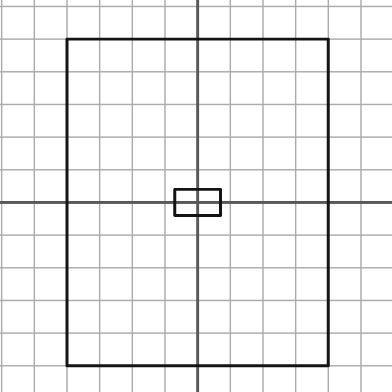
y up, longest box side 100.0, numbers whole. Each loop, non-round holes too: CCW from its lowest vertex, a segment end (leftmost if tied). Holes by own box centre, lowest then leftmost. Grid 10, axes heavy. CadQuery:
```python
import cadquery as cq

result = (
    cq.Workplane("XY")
    .moveTo(-40.0, -50.0)
    .lineTo(40.0, -50.0)
    .lineTo(40.0, 50.0)
    .lineTo(-40.0, 50.0)
    .close()
    .moveTo(-7.0, -4.0)
    .lineTo(7.0, -4.0)
    .lineTo(7.0, 4.0)
    .lineTo(-7.0, 4.0)
    .close()
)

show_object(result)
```